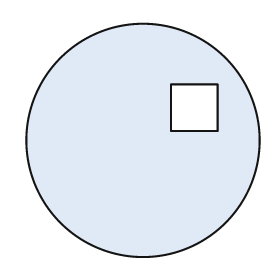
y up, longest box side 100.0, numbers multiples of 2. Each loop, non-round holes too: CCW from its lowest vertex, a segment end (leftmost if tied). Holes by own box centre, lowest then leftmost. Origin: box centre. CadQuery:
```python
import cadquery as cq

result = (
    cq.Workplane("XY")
    .moveTo(0.0, 0.0)
    .circle(50.0)
    .moveTo(12.0, 4.0)
    .lineTo(32.0, 4.0)
    .lineTo(32.0, 24.0)
    .lineTo(12.0, 24.0)
    .close()
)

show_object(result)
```